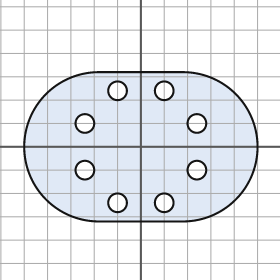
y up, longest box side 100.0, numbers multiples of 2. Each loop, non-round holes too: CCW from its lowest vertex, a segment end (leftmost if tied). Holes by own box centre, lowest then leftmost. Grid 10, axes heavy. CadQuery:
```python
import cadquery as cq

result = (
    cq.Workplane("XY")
    .moveTo(-18.0, -32.0)
    .lineTo(18.0, -32.0)
    .threePointArc((50.0, 0.0), (18.0, 32.0))
    .lineTo(-18.0, 32.0)
    .threePointArc((-50.0, 0.0), (-18.0, -32.0))
    .close()
    .moveTo(-10.0, -24.0)
    .circle(4.0)
    .moveTo(10.0, -24.0)
    .circle(4.0)
    .moveTo(-24.0, -10.0)
    .circle(4.0)
    .moveTo(24.0, -10.0)
    .circle(4.0)
    .moveTo(-24.0, 10.0)
    .circle(4.0)
    .moveTo(24.0, 10.0)
    .circle(4.0)
    .moveTo(-10.0, 24.0)
    .circle(4.0)
    .moveTo(10.0, 24.0)
    .circle(4.0)
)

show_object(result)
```